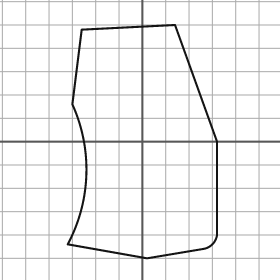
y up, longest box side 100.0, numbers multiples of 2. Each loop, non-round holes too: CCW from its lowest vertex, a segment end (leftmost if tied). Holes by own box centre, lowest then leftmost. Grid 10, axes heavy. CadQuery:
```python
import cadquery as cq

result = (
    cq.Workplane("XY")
    .moveTo(2.0, -50.0)
    .lineTo(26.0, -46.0)
    .threePointArc((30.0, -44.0), (32.0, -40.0))
    .lineTo(32.0, 0.0)
    .lineTo(14.0, 50.0)
    .lineTo(-26.0, 48.0)
    .lineTo(-30.0, 16.0)
    .threePointArc((-24.0, -14.0), (-32.0, -44.0))
    .close()
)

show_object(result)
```